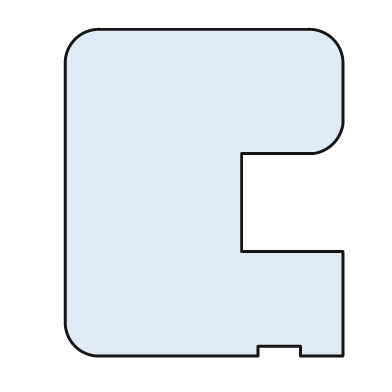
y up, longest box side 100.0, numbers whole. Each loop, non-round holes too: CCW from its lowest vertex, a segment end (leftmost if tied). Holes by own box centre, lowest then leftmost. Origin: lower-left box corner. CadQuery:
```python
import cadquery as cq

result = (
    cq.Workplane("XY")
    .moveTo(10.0, 0.0)
    .lineTo(59.0, 0.0)
    .lineTo(59.0, 3.0)
    .lineTo(72.0, 3.0)
    .lineTo(72.0, 0.0)
    .lineTo(85.0, 0.0)
    .lineTo(85.0, 32.0)
    .lineTo(54.0, 32.0)
    .lineTo(54.0, 62.0)
    .lineTo(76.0, 62.0)
    .threePointArc((82.0, 65.0), (85.0, 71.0))
    .lineTo(85.0, 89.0)
    .threePointArc((82.0, 97.0), (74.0, 100.0))
    .lineTo(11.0, 100.0)
    .threePointArc((3.0, 97.0), (0.0, 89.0))
    .lineTo(0.0, 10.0)
    .threePointArc((3.0, 3.0), (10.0, 0.0))
    .close()
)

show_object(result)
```